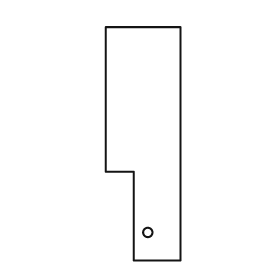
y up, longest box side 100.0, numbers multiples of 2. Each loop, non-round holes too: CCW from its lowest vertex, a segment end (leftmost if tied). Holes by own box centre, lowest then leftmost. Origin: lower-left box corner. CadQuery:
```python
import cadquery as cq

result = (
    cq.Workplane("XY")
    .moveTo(12.0, 0.0)
    .lineTo(32.0, 0.0)
    .lineTo(32.0, 100.0)
    .lineTo(0.0, 100.0)
    .lineTo(0.0, 38.0)
    .lineTo(12.0, 38.0)
    .close()
    .moveTo(18.0, 12.0)
    .circle(2.0)
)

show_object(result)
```